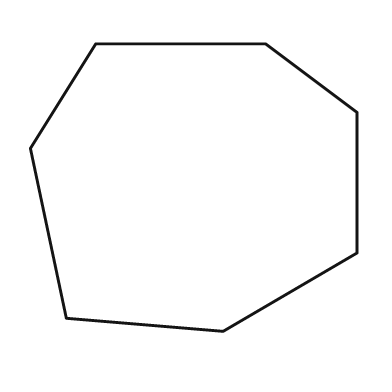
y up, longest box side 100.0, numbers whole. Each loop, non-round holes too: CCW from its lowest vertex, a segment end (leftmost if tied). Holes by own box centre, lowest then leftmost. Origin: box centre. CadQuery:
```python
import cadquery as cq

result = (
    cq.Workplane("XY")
    .moveTo(9.0, -44.0)
    .lineTo(50.0, -20.0)
    .lineTo(50.0, 23.0)
    .lineTo(22.0, 44.0)
    .lineTo(-30.0, 44.0)
    .lineTo(-50.0, 12.0)
    .lineTo(-39.0, -40.0)
    .close()
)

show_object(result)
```